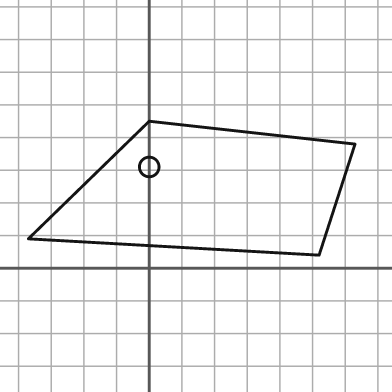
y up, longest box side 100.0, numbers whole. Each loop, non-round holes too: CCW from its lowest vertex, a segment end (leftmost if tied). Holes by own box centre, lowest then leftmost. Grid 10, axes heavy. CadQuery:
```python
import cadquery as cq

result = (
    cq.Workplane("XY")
    .moveTo(52.0, 4.0)
    .lineTo(63.0, 38.0)
    .lineTo(0.0, 45.0)
    .lineTo(-37.0, 9.0)
    .close()
    .moveTo(0.0, 31.0)
    .circle(3.0)
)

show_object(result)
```